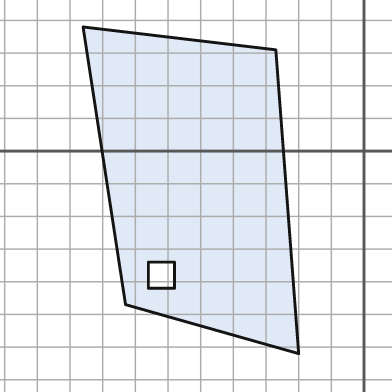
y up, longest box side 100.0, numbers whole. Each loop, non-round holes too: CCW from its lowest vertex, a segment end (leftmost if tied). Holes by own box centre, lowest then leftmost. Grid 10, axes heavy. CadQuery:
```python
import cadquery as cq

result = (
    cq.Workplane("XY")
    .moveTo(-20.0, -62.0)
    .lineTo(-27.0, 31.0)
    .lineTo(-86.0, 38.0)
    .lineTo(-73.0, -47.0)
    .close()
    .moveTo(-66.0, -42.0)
    .lineTo(-58.0, -42.0)
    .lineTo(-58.0, -34.0)
    .lineTo(-66.0, -34.0)
    .close()
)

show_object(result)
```